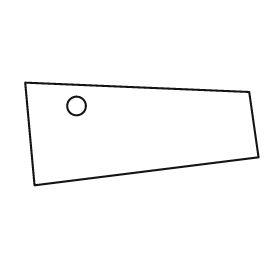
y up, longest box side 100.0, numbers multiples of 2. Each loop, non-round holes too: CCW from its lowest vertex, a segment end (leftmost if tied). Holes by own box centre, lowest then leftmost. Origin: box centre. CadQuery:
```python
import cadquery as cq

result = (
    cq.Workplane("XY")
    .moveTo(-46.0, -22.0)
    .lineTo(50.0, -10.0)
    .lineTo(46.0, 18.0)
    .lineTo(-50.0, 22.0)
    .close()
    .moveTo(-28.0, 12.0)
    .circle(4.0)
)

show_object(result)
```